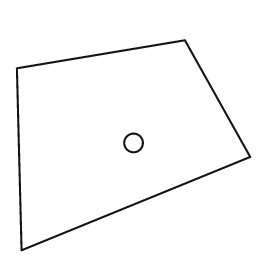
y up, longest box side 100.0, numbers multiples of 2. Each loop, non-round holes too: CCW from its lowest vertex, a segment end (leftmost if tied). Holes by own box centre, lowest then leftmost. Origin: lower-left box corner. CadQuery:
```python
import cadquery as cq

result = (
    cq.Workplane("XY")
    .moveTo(2.0, 0.0)
    .lineTo(100.0, 40.0)
    .lineTo(72.0, 90.0)
    .lineTo(0.0, 78.0)
    .close()
    .moveTo(50.0, 46.0)
    .circle(4.0)
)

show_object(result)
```